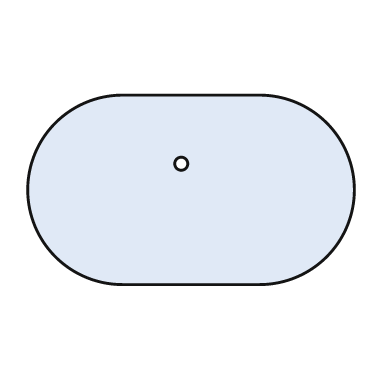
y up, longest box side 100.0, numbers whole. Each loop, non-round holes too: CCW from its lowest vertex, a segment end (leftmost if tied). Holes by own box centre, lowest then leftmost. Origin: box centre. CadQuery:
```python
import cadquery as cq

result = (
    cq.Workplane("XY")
    .moveTo(-21.0, -29.0)
    .lineTo(21.0, -29.0)
    .threePointArc((50.0, 0.0), (21.0, 29.0))
    .lineTo(-21.0, 29.0)
    .threePointArc((-50.0, 0.0), (-21.0, -29.0))
    .close()
    .moveTo(-3.0, 8.0)
    .circle(2.0)
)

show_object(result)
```